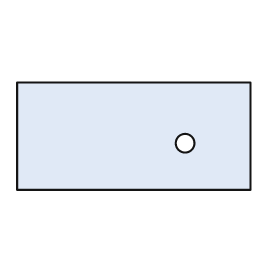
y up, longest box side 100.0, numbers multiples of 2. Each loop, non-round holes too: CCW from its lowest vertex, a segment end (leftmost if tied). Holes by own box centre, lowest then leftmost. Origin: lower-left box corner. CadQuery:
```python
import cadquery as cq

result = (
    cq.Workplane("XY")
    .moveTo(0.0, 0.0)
    .lineTo(100.0, 0.0)
    .lineTo(100.0, 46.0)
    .lineTo(0.0, 46.0)
    .close()
    .moveTo(72.0, 20.0)
    .circle(4.0)
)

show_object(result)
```